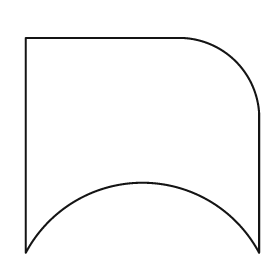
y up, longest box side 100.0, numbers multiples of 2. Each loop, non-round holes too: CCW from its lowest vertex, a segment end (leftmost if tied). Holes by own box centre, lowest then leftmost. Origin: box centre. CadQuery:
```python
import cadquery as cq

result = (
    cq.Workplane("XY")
    .moveTo(-50.0, -46.0)
    .threePointArc((0.0, -16.0), (50.0, -46.0))
    .lineTo(50.0, 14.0)
    .threePointArc((40.0, 36.0), (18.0, 46.0))
    .lineTo(-50.0, 46.0)
    .close()
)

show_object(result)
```